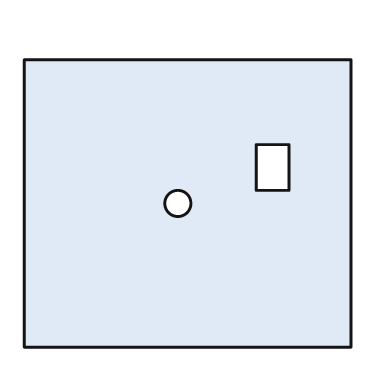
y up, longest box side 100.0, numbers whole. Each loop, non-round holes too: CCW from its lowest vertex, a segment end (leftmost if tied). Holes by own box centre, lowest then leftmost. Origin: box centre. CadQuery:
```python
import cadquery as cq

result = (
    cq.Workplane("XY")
    .moveTo(-50.0, -44.0)
    .lineTo(50.0, -44.0)
    .lineTo(50.0, 44.0)
    .lineTo(-50.0, 44.0)
    .close()
    .moveTo(-3.0, 0.0)
    .circle(4.0)
    .moveTo(21.0, 4.0)
    .lineTo(31.0, 4.0)
    .lineTo(31.0, 18.0)
    .lineTo(21.0, 18.0)
    .close()
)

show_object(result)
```